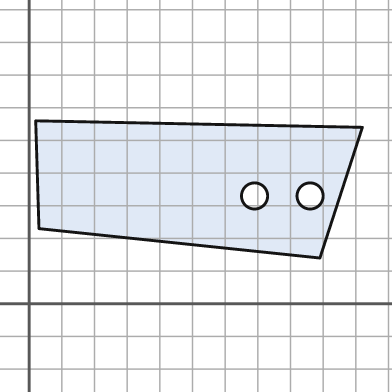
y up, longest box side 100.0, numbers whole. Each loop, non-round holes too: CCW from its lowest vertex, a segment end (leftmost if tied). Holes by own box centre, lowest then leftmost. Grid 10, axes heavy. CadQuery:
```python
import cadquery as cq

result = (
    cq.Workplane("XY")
    .moveTo(89.0, 14.0)
    .lineTo(102.0, 54.0)
    .lineTo(2.0, 56.0)
    .lineTo(3.0, 23.0)
    .close()
    .moveTo(69.0, 33.0)
    .circle(4.0)
    .moveTo(86.0, 33.0)
    .circle(4.0)
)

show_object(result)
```